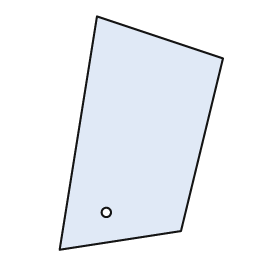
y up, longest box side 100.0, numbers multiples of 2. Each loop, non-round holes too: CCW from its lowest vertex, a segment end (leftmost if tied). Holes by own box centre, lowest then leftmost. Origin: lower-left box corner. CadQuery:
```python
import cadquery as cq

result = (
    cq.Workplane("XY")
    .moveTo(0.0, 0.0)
    .lineTo(52.0, 8.0)
    .lineTo(70.0, 82.0)
    .lineTo(16.0, 100.0)
    .close()
    .moveTo(20.0, 16.0)
    .circle(2.0)
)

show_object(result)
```